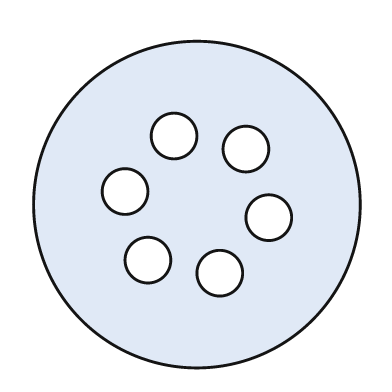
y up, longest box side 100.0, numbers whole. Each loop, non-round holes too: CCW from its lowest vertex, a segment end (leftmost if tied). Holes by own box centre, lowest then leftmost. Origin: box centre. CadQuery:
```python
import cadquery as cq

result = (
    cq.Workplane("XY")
    .moveTo(0.0, 0.0)
    .circle(50.0)
    .moveTo(7.0, -21.0)
    .circle(7.0)
    .moveTo(-15.0, -17.0)
    .circle(7.0)
    .moveTo(22.0, -4.0)
    .circle(7.0)
    .moveTo(-22.0, 4.0)
    .circle(7.0)
    .moveTo(15.0, 17.0)
    .circle(7.0)
    .moveTo(-7.0, 21.0)
    .circle(7.0)
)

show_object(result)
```